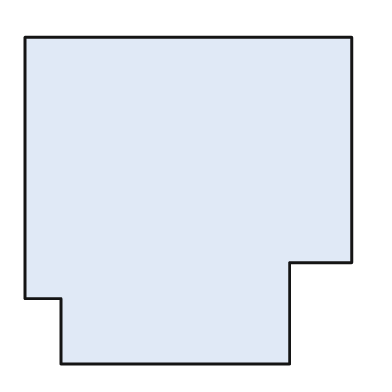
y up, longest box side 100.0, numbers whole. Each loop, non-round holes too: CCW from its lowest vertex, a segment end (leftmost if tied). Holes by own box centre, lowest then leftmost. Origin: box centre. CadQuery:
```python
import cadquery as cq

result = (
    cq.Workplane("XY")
    .moveTo(-39.0, -50.0)
    .lineTo(31.0, -50.0)
    .lineTo(31.0, -19.0)
    .lineTo(50.0, -19.0)
    .lineTo(50.0, 50.0)
    .lineTo(-50.0, 50.0)
    .lineTo(-50.0, -30.0)
    .lineTo(-39.0, -30.0)
    .close()
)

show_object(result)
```